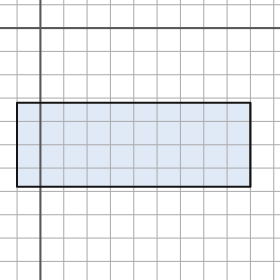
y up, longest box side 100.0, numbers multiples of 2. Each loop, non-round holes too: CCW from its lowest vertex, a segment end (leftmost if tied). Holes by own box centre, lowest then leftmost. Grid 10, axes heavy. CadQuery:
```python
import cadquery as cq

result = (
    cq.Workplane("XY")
    .moveTo(-10.0, -68.0)
    .lineTo(90.0, -68.0)
    .lineTo(90.0, -32.0)
    .lineTo(-10.0, -32.0)
    .close()
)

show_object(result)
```